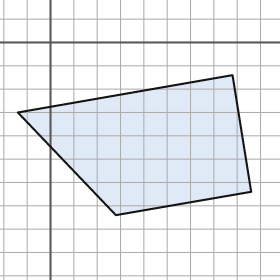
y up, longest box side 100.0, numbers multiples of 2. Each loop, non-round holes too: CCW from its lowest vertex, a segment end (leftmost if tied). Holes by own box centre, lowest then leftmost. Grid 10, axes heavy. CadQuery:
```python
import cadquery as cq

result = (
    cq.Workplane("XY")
    .moveTo(28.0, -74.0)
    .lineTo(86.0, -64.0)
    .lineTo(78.0, -14.0)
    .lineTo(-14.0, -30.0)
    .close()
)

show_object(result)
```